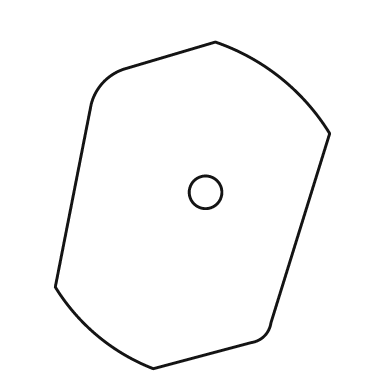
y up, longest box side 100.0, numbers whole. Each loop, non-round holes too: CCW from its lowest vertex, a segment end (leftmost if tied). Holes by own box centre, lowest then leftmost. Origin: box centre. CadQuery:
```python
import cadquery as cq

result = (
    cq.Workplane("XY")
    .moveTo(-12.0, -50.0)
    .lineTo(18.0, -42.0)
    .threePointArc((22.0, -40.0), (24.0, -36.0))
    .lineTo(42.0, 22.0)
    .threePointArc((27.0, 39.0), (7.0, 50.0))
    .lineTo(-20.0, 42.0)
    .threePointArc((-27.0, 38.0), (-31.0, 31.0))
    .lineTo(-42.0, -25.0)
    .threePointArc((-29.0, -40.0), (-12.0, -50.0))
    .close()
    .moveTo(4.0, 4.0)
    .circle(5.0)
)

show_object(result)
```